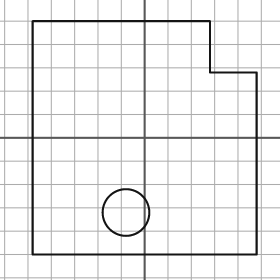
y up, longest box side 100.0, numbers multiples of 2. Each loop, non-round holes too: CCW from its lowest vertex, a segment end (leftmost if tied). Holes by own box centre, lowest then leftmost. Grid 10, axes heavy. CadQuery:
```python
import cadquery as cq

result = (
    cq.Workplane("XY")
    .moveTo(-48.0, -50.0)
    .lineTo(48.0, -50.0)
    .lineTo(48.0, 28.0)
    .lineTo(28.0, 28.0)
    .lineTo(28.0, 50.0)
    .lineTo(-48.0, 50.0)
    .close()
    .moveTo(-8.0, -32.0)
    .circle(10.0)
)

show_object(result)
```